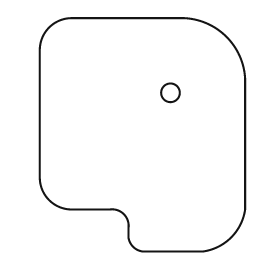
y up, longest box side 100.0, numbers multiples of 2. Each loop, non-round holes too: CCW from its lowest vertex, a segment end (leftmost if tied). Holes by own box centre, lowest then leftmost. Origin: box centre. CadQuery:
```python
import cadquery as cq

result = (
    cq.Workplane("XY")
    .moveTo(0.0, -50.0)
    .lineTo(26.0, -50.0)
    .threePointArc((38.0, -44.0), (44.0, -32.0))
    .lineTo(44.0, 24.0)
    .threePointArc((36.0, 42.0), (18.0, 50.0))
    .lineTo(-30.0, 50.0)
    .threePointArc((-40.0, 46.0), (-44.0, 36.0))
    .lineTo(-44.0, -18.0)
    .threePointArc((-40.0, -28.0), (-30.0, -32.0))
    .lineTo(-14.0, -32.0)
    .threePointArc((-8.0, -34.0), (-6.0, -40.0))
    .lineTo(-6.0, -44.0)
    .threePointArc((-4.0, -48.0), (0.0, -50.0))
    .close()
    .moveTo(12.0, 18.0)
    .circle(4.0)
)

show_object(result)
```